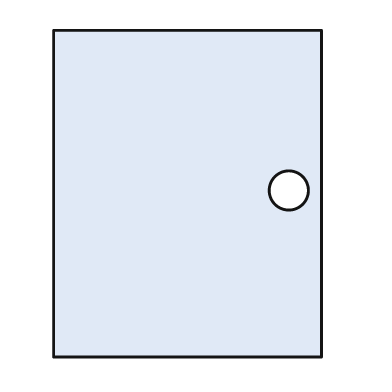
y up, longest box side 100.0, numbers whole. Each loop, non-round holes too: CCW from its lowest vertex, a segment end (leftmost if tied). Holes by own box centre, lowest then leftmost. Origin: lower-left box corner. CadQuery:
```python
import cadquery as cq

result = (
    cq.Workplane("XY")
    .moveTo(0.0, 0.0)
    .lineTo(82.0, 0.0)
    .lineTo(82.0, 100.0)
    .lineTo(0.0, 100.0)
    .close()
    .moveTo(72.0, 51.0)
    .circle(6.0)
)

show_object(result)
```